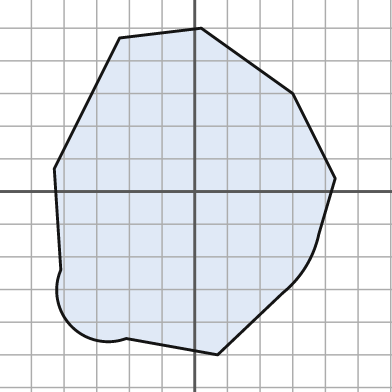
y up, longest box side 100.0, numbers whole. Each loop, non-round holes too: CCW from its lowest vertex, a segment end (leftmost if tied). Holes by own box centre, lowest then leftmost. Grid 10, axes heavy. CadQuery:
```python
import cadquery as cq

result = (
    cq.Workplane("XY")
    .moveTo(7.0, -50.0)
    .lineTo(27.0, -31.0)
    .threePointArc((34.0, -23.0), (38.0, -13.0))
    .lineTo(43.0, 4.0)
    .lineTo(30.0, 30.0)
    .lineTo(2.0, 50.0)
    .lineTo(-23.0, 47.0)
    .lineTo(-43.0, 7.0)
    .lineTo(-41.0, -24.0)
    .threePointArc((-38.0, -41.0), (-21.0, -45.0))
    .close()
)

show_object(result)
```